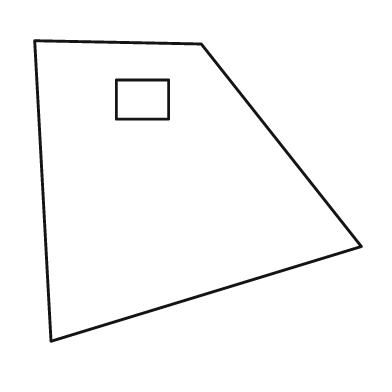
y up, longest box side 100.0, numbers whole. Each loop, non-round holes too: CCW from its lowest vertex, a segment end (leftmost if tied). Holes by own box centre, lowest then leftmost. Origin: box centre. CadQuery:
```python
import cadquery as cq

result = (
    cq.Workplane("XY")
    .moveTo(-45.0, -46.0)
    .lineTo(50.0, -17.0)
    .lineTo(1.0, 45.0)
    .lineTo(-50.0, 46.0)
    .close()
    .moveTo(-25.0, 22.0)
    .lineTo(-9.0, 22.0)
    .lineTo(-9.0, 34.0)
    .lineTo(-25.0, 34.0)
    .close()
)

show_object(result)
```